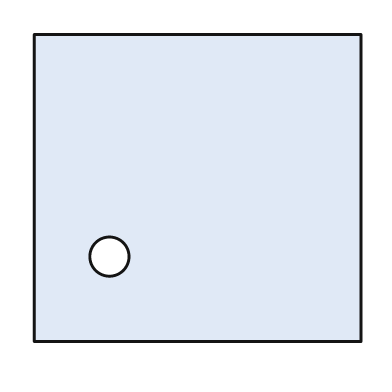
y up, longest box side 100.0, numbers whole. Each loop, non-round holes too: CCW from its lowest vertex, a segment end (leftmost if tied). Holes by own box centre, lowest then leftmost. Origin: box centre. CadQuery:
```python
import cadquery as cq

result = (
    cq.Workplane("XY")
    .moveTo(-50.0, -47.0)
    .lineTo(50.0, -47.0)
    .lineTo(50.0, 47.0)
    .lineTo(-50.0, 47.0)
    .close()
    .moveTo(-27.0, -21.0)
    .circle(6.0)
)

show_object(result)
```